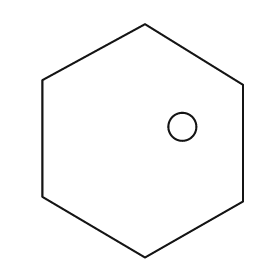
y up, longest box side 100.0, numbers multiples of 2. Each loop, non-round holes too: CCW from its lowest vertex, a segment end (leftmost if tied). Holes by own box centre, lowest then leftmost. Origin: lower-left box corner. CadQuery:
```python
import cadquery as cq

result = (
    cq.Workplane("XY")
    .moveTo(44.0, 0.0)
    .lineTo(86.0, 24.0)
    .lineTo(86.0, 74.0)
    .lineTo(44.0, 100.0)
    .lineTo(0.0, 76.0)
    .lineTo(0.0, 26.0)
    .close()
    .moveTo(60.0, 56.0)
    .circle(6.0)
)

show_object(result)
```